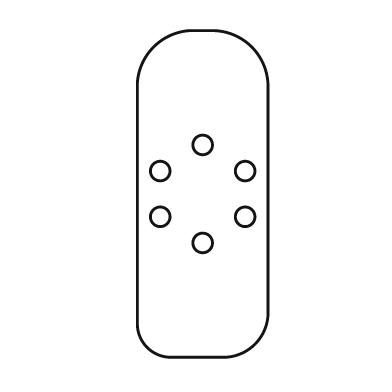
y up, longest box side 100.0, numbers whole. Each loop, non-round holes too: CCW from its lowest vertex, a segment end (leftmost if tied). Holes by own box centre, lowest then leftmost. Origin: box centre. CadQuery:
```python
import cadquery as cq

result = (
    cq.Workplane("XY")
    .moveTo(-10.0, -50.0)
    .lineTo(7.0, -50.0)
    .threePointArc((16.0, -46.0), (20.0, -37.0))
    .lineTo(20.0, 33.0)
    .threePointArc((15.0, 45.0), (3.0, 50.0))
    .lineTo(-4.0, 50.0)
    .threePointArc((-15.0, 45.0), (-20.0, 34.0))
    .lineTo(-20.0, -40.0)
    .threePointArc((-17.0, -47.0), (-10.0, -50.0))
    .close()
    .moveTo(0.0, -15.0)
    .circle(3.0)
    .moveTo(-13.0, -7.0)
    .circle(3.0)
    .moveTo(13.0, -7.0)
    .circle(3.0)
    .moveTo(-13.0, 7.0)
    .circle(3.0)
    .moveTo(13.0, 7.0)
    .circle(3.0)
    .moveTo(0.0, 15.0)
    .circle(3.0)
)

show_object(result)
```